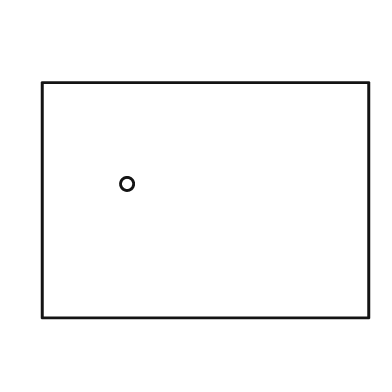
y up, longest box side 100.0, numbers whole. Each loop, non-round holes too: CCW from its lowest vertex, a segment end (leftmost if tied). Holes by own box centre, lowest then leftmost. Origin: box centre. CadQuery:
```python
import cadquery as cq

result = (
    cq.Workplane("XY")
    .moveTo(-50.0, -36.0)
    .lineTo(50.0, -36.0)
    .lineTo(50.0, 36.0)
    .lineTo(-50.0, 36.0)
    .close()
    .moveTo(-24.0, 5.0)
    .circle(2.0)
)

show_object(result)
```